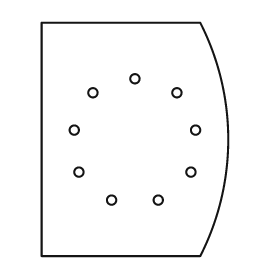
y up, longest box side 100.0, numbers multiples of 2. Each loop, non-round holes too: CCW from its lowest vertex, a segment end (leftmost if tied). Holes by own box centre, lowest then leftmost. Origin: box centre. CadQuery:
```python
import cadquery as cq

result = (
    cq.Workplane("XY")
    .moveTo(-40.0, -50.0)
    .lineTo(28.0, -50.0)
    .threePointArc((40.0, 0.0), (28.0, 50.0))
    .lineTo(-40.0, 50.0)
    .close()
    .moveTo(-10.0, -26.0)
    .circle(2.0)
    .moveTo(10.0, -26.0)
    .circle(2.0)
    .moveTo(-24.0, -14.0)
    .circle(2.0)
    .moveTo(24.0, -14.0)
    .circle(2.0)
    .moveTo(-26.0, 4.0)
    .circle(2.0)
    .moveTo(26.0, 4.0)
    .circle(2.0)
    .moveTo(-18.0, 20.0)
    .circle(2.0)
    .moveTo(18.0, 20.0)
    .circle(2.0)
    .moveTo(0.0, 26.0)
    .circle(2.0)
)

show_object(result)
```